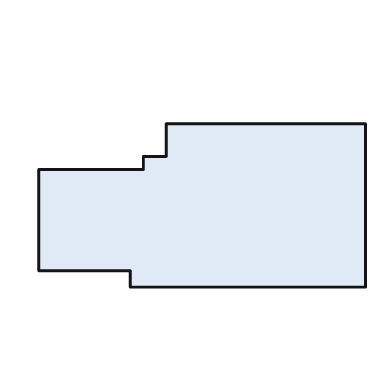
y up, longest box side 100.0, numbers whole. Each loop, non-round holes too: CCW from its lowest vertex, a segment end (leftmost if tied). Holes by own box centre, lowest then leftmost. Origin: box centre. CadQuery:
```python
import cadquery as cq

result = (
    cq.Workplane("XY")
    .moveTo(-22.0, -25.0)
    .lineTo(50.0, -25.0)
    .lineTo(50.0, 25.0)
    .lineTo(-11.0, 25.0)
    .lineTo(-11.0, 15.0)
    .lineTo(-18.0, 15.0)
    .lineTo(-18.0, 11.0)
    .lineTo(-50.0, 11.0)
    .lineTo(-50.0, -20.0)
    .lineTo(-22.0, -20.0)
    .close()
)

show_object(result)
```